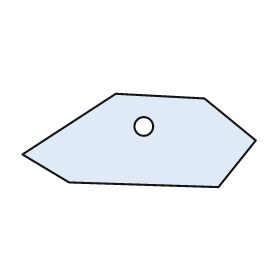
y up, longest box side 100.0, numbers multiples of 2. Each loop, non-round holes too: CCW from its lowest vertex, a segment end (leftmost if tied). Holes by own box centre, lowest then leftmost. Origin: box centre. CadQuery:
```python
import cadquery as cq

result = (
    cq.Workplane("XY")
    .moveTo(34.0, -20.0)
    .lineTo(50.0, 0.0)
    .lineTo(28.0, 18.0)
    .lineTo(-10.0, 20.0)
    .lineTo(-50.0, -6.0)
    .lineTo(-30.0, -18.0)
    .close()
    .moveTo(2.0, 6.0)
    .circle(4.0)
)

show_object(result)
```